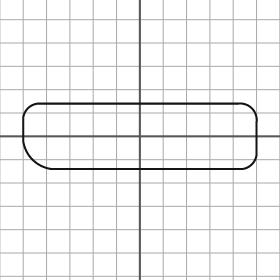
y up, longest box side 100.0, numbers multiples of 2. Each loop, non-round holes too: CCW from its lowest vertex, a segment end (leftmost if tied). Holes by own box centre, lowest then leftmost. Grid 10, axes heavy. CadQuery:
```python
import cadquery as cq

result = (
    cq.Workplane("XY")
    .moveTo(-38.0, -14.0)
    .lineTo(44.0, -14.0)
    .threePointArc((48.0, -12.0), (50.0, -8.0))
    .lineTo(50.0, 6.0)
    .threePointArc((48.0, 12.0), (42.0, 14.0))
    .lineTo(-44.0, 14.0)
    .threePointArc((-48.0, 12.0), (-50.0, 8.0))
    .lineTo(-50.0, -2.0)
    .threePointArc((-46.0, -10.0), (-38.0, -14.0))
    .close()
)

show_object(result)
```